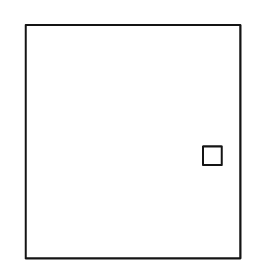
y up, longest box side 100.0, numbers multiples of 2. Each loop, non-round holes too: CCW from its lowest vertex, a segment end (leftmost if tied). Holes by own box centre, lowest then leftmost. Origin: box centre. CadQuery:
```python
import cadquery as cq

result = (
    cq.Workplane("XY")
    .moveTo(-46.0, -50.0)
    .lineTo(46.0, -50.0)
    .lineTo(46.0, 50.0)
    .lineTo(-46.0, 50.0)
    .close()
    .moveTo(30.0, -10.0)
    .lineTo(38.0, -10.0)
    .lineTo(38.0, -2.0)
    .lineTo(30.0, -2.0)
    .close()
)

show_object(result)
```